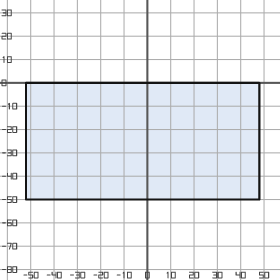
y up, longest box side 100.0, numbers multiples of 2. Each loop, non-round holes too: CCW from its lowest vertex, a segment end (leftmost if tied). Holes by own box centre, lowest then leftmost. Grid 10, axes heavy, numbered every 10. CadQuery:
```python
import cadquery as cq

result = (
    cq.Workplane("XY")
    .moveTo(-52.0, -50.0)
    .lineTo(48.0, -50.0)
    .lineTo(48.0, 0.0)
    .lineTo(-52.0, 0.0)
    .close()
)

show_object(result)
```